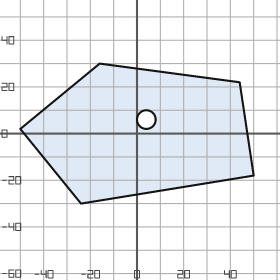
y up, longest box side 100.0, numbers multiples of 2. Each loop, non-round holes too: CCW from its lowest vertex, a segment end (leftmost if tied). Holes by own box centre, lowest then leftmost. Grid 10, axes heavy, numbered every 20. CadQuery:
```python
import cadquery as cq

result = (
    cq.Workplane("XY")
    .moveTo(-24.0, -30.0)
    .lineTo(50.0, -18.0)
    .lineTo(44.0, 22.0)
    .lineTo(-16.0, 30.0)
    .lineTo(-50.0, 2.0)
    .close()
    .moveTo(4.0, 6.0)
    .circle(4.0)
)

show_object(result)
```